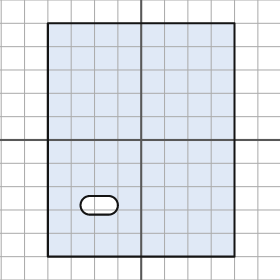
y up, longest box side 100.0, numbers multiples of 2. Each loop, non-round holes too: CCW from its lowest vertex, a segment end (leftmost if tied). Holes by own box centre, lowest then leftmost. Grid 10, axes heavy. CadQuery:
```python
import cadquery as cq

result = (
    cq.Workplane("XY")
    .moveTo(-40.0, -50.0)
    .lineTo(40.0, -50.0)
    .lineTo(40.0, 50.0)
    .lineTo(-40.0, 50.0)
    .close()
    .moveTo(-22.0, -32.0)
    .lineTo(-14.0, -32.0)
    .threePointArc((-10.0, -28.0), (-14.0, -24.0))
    .lineTo(-22.0, -24.0)
    .threePointArc((-26.0, -28.0), (-22.0, -32.0))
    .close()
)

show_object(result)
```